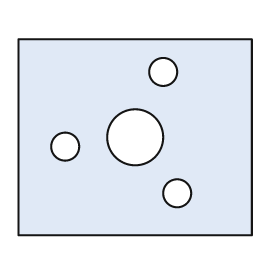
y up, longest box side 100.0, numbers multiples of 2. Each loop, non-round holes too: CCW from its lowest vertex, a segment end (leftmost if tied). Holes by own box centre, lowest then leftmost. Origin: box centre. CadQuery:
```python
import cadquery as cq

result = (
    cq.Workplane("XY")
    .moveTo(-50.0, -42.0)
    .lineTo(50.0, -42.0)
    .lineTo(50.0, 42.0)
    .lineTo(-50.0, 42.0)
    .close()
    .moveTo(18.0, -24.0)
    .circle(6.0)
    .moveTo(-30.0, -4.0)
    .circle(6.0)
    .moveTo(0.0, 0.0)
    .circle(12.0)
    .moveTo(12.0, 28.0)
    .circle(6.0)
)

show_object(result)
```